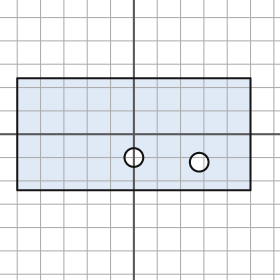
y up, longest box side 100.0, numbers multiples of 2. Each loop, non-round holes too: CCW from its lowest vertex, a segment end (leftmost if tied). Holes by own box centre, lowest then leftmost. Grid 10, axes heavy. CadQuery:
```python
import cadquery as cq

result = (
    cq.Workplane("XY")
    .moveTo(-50.0, -24.0)
    .lineTo(50.0, -24.0)
    .lineTo(50.0, 24.0)
    .lineTo(-50.0, 24.0)
    .close()
    .moveTo(28.0, -12.0)
    .circle(4.0)
    .moveTo(0.0, -10.0)
    .circle(4.0)
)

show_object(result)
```